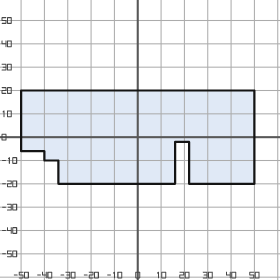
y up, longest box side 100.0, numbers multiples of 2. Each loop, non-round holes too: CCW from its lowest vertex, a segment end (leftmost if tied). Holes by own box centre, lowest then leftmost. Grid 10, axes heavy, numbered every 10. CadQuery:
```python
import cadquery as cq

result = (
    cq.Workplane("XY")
    .moveTo(-34.0, -20.0)
    .lineTo(16.0, -20.0)
    .lineTo(16.0, -2.0)
    .lineTo(22.0, -2.0)
    .lineTo(22.0, -20.0)
    .lineTo(50.0, -20.0)
    .lineTo(50.0, 20.0)
    .lineTo(-50.0, 20.0)
    .lineTo(-50.0, -6.0)
    .lineTo(-40.0, -6.0)
    .lineTo(-40.0, -10.0)
    .lineTo(-34.0, -10.0)
    .close()
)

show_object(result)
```